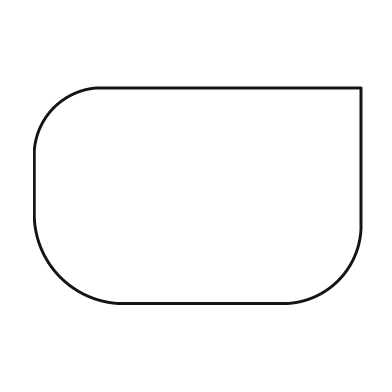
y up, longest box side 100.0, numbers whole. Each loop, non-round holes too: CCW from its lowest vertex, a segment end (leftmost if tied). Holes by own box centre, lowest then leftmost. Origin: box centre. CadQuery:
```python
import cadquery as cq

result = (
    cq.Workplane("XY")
    .moveTo(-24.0, -33.0)
    .lineTo(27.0, -33.0)
    .threePointArc((43.0, -26.0), (50.0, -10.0))
    .lineTo(50.0, 33.0)
    .lineTo(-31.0, 33.0)
    .threePointArc((-44.0, 27.0), (-50.0, 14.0))
    .lineTo(-50.0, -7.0)
    .threePointArc((-42.0, -25.0), (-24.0, -33.0))
    .close()
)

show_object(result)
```